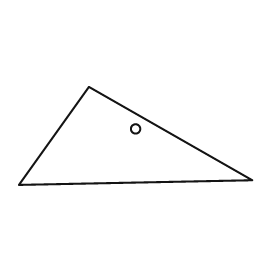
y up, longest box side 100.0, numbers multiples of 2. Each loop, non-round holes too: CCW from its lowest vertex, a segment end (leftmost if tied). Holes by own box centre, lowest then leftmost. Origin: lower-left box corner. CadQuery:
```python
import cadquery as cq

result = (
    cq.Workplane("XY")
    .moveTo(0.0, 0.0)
    .lineTo(100.0, 2.0)
    .lineTo(30.0, 42.0)
    .close()
    .moveTo(50.0, 24.0)
    .circle(2.0)
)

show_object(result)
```